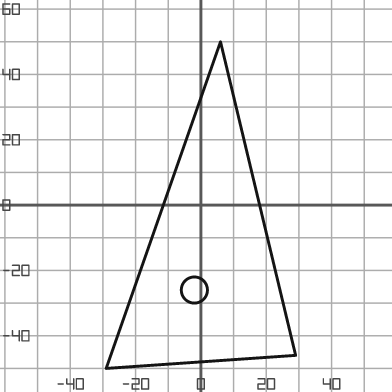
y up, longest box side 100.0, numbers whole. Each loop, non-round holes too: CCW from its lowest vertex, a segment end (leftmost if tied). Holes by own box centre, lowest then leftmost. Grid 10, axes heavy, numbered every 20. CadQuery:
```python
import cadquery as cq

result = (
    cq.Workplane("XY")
    .moveTo(-29.0, -50.0)
    .lineTo(29.0, -46.0)
    .lineTo(6.0, 50.0)
    .close()
    .moveTo(-2.0, -26.0)
    .circle(4.0)
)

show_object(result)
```